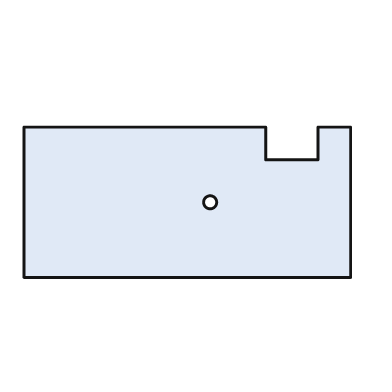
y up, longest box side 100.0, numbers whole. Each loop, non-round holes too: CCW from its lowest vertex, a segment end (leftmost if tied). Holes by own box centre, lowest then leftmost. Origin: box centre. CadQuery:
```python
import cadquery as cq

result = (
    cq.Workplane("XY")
    .moveTo(-50.0, -23.0)
    .lineTo(50.0, -23.0)
    .lineTo(50.0, 23.0)
    .lineTo(40.0, 23.0)
    .lineTo(40.0, 13.0)
    .lineTo(24.0, 13.0)
    .lineTo(24.0, 23.0)
    .lineTo(-50.0, 23.0)
    .close()
    .moveTo(7.0, 0.0)
    .circle(2.0)
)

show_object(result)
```